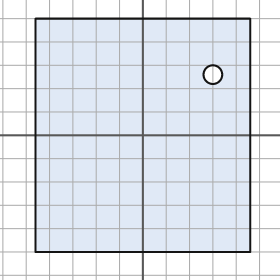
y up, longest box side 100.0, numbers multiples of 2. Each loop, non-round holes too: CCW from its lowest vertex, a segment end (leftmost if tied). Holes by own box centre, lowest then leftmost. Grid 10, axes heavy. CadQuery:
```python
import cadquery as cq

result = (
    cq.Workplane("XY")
    .moveTo(-46.0, -50.0)
    .lineTo(46.0, -50.0)
    .lineTo(46.0, 50.0)
    .lineTo(-46.0, 50.0)
    .close()
    .moveTo(30.0, 26.0)
    .circle(4.0)
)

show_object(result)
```